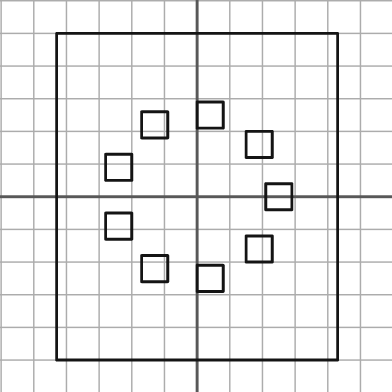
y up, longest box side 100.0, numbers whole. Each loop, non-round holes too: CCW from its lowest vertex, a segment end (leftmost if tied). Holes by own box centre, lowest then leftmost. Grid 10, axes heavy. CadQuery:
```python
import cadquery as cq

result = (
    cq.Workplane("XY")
    .moveTo(-43.0, -50.0)
    .lineTo(43.0, -50.0)
    .lineTo(43.0, 50.0)
    .lineTo(-43.0, 50.0)
    .close()
    .moveTo(0.0, -29.0)
    .lineTo(8.0, -29.0)
    .lineTo(8.0, -21.0)
    .lineTo(0.0, -21.0)
    .close()
    .moveTo(-17.0, -26.0)
    .lineTo(-9.0, -26.0)
    .lineTo(-9.0, -18.0)
    .lineTo(-17.0, -18.0)
    .close()
    .moveTo(15.0, -20.0)
    .lineTo(23.0, -20.0)
    .lineTo(23.0, -12.0)
    .lineTo(15.0, -12.0)
    .close()
    .moveTo(-28.0, -13.0)
    .lineTo(-20.0, -13.0)
    .lineTo(-20.0, -5.0)
    .lineTo(-28.0, -5.0)
    .close()
    .moveTo(21.0, -4.0)
    .lineTo(29.0, -4.0)
    .lineTo(29.0, 4.0)
    .lineTo(21.0, 4.0)
    .close()
    .moveTo(-28.0, 5.0)
    .lineTo(-20.0, 5.0)
    .lineTo(-20.0, 13.0)
    .lineTo(-28.0, 13.0)
    .close()
    .moveTo(15.0, 12.0)
    .lineTo(23.0, 12.0)
    .lineTo(23.0, 20.0)
    .lineTo(15.0, 20.0)
    .close()
    .moveTo(-17.0, 18.0)
    .lineTo(-9.0, 18.0)
    .lineTo(-9.0, 26.0)
    .lineTo(-17.0, 26.0)
    .close()
    .moveTo(0.0, 21.0)
    .lineTo(8.0, 21.0)
    .lineTo(8.0, 29.0)
    .lineTo(0.0, 29.0)
    .close()
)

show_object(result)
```